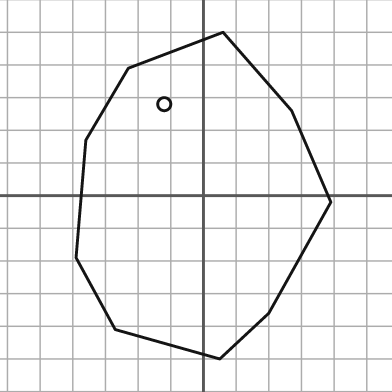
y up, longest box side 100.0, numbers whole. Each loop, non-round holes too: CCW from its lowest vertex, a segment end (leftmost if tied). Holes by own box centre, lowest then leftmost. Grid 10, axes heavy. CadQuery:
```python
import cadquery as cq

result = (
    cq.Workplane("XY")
    .moveTo(5.0, -50.0)
    .lineTo(20.0, -36.0)
    .lineTo(39.0, -2.0)
    .lineTo(27.0, 26.0)
    .lineTo(6.0, 50.0)
    .lineTo(-23.0, 39.0)
    .lineTo(-36.0, 17.0)
    .lineTo(-39.0, -19.0)
    .lineTo(-27.0, -41.0)
    .close()
    .moveTo(-12.0, 28.0)
    .circle(2.0)
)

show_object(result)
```